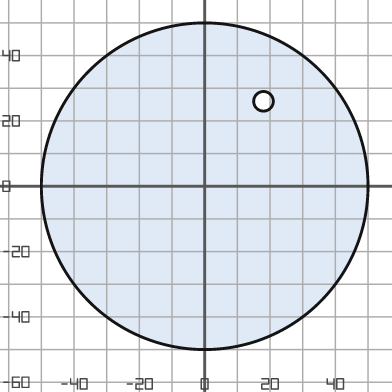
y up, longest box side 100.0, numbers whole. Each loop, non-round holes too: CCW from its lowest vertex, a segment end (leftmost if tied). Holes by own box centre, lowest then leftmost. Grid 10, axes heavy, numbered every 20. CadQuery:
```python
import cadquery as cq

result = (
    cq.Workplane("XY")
    .moveTo(0.0, 0.0)
    .circle(50.0)
    .moveTo(18.0, 26.0)
    .circle(3.0)
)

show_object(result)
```